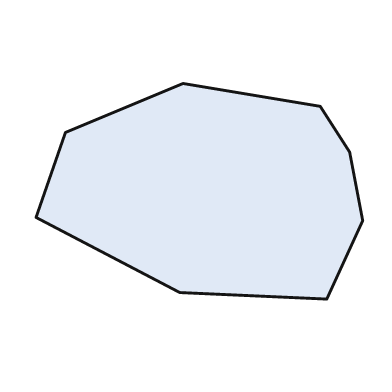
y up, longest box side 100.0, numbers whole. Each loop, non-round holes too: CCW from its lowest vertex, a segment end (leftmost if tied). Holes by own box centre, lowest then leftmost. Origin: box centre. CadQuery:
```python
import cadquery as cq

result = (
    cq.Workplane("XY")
    .moveTo(39.0, -33.0)
    .lineTo(50.0, -9.0)
    .lineTo(46.0, 12.0)
    .lineTo(37.0, 26.0)
    .lineTo(-5.0, 33.0)
    .lineTo(-41.0, 18.0)
    .lineTo(-50.0, -8.0)
    .lineTo(-6.0, -31.0)
    .close()
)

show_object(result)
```